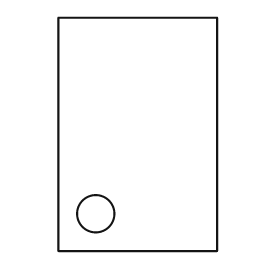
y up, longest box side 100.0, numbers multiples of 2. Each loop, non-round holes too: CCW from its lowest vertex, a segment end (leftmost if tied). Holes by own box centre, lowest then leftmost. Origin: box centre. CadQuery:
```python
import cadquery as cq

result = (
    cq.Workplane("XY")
    .moveTo(-34.0, -50.0)
    .lineTo(34.0, -50.0)
    .lineTo(34.0, 50.0)
    .lineTo(-34.0, 50.0)
    .close()
    .moveTo(-18.0, -34.0)
    .circle(8.0)
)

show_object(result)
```